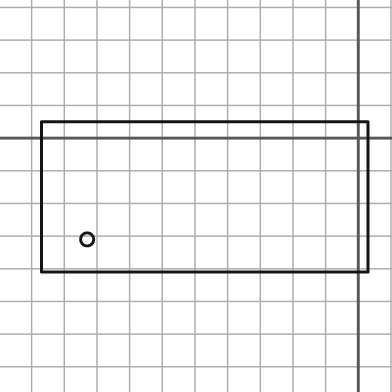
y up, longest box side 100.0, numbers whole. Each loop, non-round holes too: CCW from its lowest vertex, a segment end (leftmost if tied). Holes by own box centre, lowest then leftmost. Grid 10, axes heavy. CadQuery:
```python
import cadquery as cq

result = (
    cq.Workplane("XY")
    .moveTo(-97.0, -41.0)
    .lineTo(3.0, -41.0)
    .lineTo(3.0, 5.0)
    .lineTo(-97.0, 5.0)
    .close()
    .moveTo(-83.0, -31.0)
    .circle(2.0)
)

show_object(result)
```